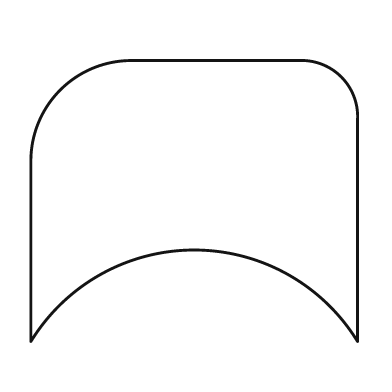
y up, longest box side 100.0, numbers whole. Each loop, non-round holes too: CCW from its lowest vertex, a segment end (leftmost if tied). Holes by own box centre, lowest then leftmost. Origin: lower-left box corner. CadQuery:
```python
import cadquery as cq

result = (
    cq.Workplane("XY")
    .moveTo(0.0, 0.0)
    .threePointArc((50.0, 28.0), (100.0, 0.0))
    .lineTo(100.0, 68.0)
    .threePointArc((95.0, 81.0), (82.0, 86.0))
    .lineTo(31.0, 86.0)
    .threePointArc((9.0, 77.0), (0.0, 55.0))
    .close()
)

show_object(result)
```